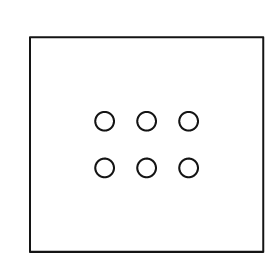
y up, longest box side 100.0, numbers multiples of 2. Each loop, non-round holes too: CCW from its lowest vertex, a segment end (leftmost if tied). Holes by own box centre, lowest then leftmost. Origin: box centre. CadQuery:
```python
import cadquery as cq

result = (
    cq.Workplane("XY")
    .moveTo(-50.0, -46.0)
    .lineTo(50.0, -46.0)
    .lineTo(50.0, 46.0)
    .lineTo(-50.0, 46.0)
    .close()
    .moveTo(-18.0, -10.0)
    .circle(4.0)
    .moveTo(0.0, -10.0)
    .circle(4.0)
    .moveTo(18.0, -10.0)
    .circle(4.0)
    .moveTo(-18.0, 10.0)
    .circle(4.0)
    .moveTo(0.0, 10.0)
    .circle(4.0)
    .moveTo(18.0, 10.0)
    .circle(4.0)
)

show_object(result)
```